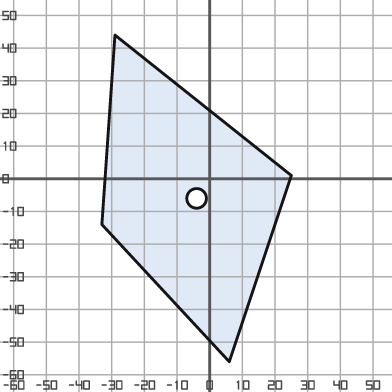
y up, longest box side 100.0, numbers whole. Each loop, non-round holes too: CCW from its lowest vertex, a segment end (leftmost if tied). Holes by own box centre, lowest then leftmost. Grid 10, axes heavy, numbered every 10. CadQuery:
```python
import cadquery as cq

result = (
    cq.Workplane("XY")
    .moveTo(6.0, -56.0)
    .lineTo(25.0, 1.0)
    .lineTo(-29.0, 44.0)
    .lineTo(-33.0, -14.0)
    .close()
    .moveTo(-4.0, -6.0)
    .circle(3.0)
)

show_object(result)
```